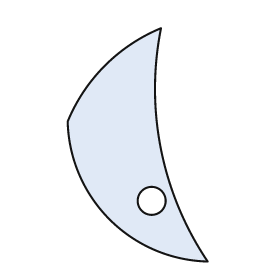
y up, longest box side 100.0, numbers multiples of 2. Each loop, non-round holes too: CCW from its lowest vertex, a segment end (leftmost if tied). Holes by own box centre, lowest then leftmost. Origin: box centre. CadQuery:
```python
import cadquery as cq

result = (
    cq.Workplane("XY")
    .moveTo(30.0, -50.0)
    .threePointArc((10.0, -2.0), (10.0, 50.0))
    .threePointArc((-14.0, 34.0), (-30.0, 10.0))
    .threePointArc((-12.0, -32.0), (30.0, -50.0))
    .close()
    .moveTo(6.0, -24.0)
    .circle(6.0)
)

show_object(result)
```